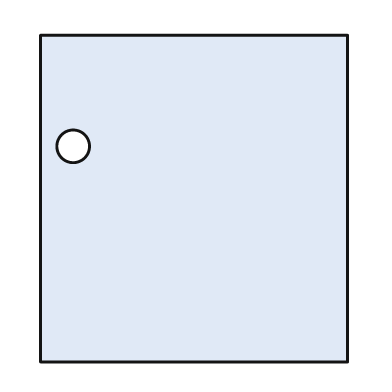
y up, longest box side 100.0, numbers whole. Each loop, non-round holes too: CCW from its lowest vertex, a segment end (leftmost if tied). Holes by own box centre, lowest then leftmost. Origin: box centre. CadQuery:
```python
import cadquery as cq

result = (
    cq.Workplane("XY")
    .moveTo(-47.0, -50.0)
    .lineTo(47.0, -50.0)
    .lineTo(47.0, 50.0)
    .lineTo(-47.0, 50.0)
    .close()
    .moveTo(-37.0, 16.0)
    .circle(5.0)
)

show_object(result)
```